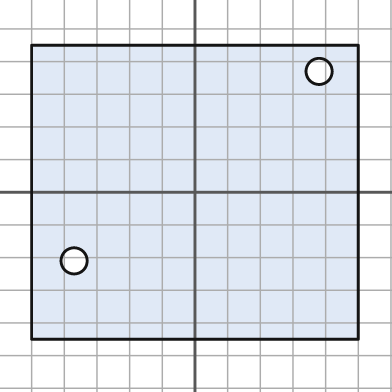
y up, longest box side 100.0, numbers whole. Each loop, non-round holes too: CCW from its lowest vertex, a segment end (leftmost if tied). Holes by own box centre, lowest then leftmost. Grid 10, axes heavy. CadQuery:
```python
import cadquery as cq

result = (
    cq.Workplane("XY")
    .moveTo(-50.0, -45.0)
    .lineTo(50.0, -45.0)
    .lineTo(50.0, 45.0)
    .lineTo(-50.0, 45.0)
    .close()
    .moveTo(-37.0, -21.0)
    .circle(4.0)
    .moveTo(38.0, 37.0)
    .circle(4.0)
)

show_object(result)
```